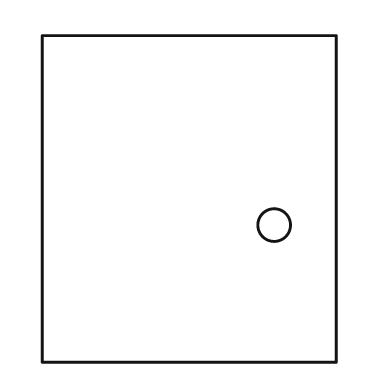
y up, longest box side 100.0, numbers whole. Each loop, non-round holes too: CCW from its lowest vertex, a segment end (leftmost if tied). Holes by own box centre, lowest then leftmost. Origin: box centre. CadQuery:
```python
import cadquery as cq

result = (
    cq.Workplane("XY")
    .moveTo(-45.0, -50.0)
    .lineTo(45.0, -50.0)
    .lineTo(45.0, 50.0)
    .lineTo(-45.0, 50.0)
    .close()
    .moveTo(26.0, -8.0)
    .circle(5.0)
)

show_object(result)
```